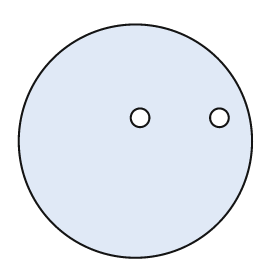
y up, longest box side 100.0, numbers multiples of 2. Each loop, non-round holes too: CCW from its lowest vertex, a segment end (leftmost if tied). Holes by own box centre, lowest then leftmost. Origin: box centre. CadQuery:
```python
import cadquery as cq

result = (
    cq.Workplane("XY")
    .moveTo(0.0, 0.0)
    .circle(50.0)
    .moveTo(2.0, 10.0)
    .circle(4.0)
    .moveTo(36.0, 10.0)
    .circle(4.0)
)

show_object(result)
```